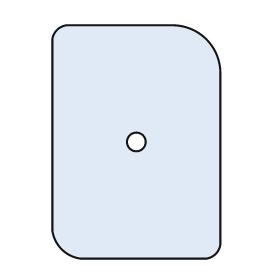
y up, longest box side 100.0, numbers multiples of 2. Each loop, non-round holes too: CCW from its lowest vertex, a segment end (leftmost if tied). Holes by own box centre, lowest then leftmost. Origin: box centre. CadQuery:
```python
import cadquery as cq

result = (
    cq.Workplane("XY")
    .moveTo(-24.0, -50.0)
    .lineTo(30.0, -50.0)
    .threePointArc((34.0, -48.0), (36.0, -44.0))
    .lineTo(36.0, 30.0)
    .threePointArc((30.0, 44.0), (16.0, 50.0))
    .lineTo(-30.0, 50.0)
    .threePointArc((-34.0, 48.0), (-36.0, 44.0))
    .lineTo(-36.0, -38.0)
    .threePointArc((-32.0, -46.0), (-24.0, -50.0))
    .close()
    .moveTo(0.0, 0.0)
    .circle(4.0)
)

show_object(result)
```